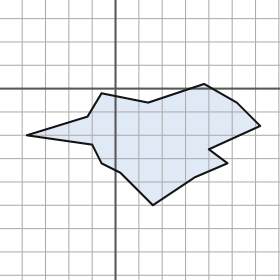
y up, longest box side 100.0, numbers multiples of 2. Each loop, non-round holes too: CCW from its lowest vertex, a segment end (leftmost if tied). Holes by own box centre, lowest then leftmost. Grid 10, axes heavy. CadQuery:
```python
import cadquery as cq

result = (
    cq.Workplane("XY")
    .moveTo(16.0, -50.0)
    .lineTo(34.0, -38.0)
    .lineTo(48.0, -32.0)
    .lineTo(40.0, -26.0)
    .lineTo(62.0, -16.0)
    .lineTo(52.0, -6.0)
    .lineTo(38.0, 2.0)
    .lineTo(14.0, -6.0)
    .lineTo(-6.0, -2.0)
    .lineTo(-12.0, -12.0)
    .lineTo(-38.0, -20.0)
    .lineTo(-10.0, -24.0)
    .lineTo(-6.0, -32.0)
    .lineTo(2.0, -36.0)
    .close()
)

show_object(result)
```